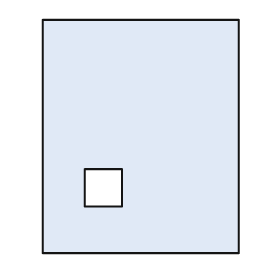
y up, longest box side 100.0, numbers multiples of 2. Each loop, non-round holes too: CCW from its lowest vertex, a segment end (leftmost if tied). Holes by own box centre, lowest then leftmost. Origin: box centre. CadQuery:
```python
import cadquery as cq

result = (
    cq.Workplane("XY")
    .moveTo(-42.0, -50.0)
    .lineTo(42.0, -50.0)
    .lineTo(42.0, 50.0)
    .lineTo(-42.0, 50.0)
    .close()
    .moveTo(-24.0, -30.0)
    .lineTo(-8.0, -30.0)
    .lineTo(-8.0, -14.0)
    .lineTo(-24.0, -14.0)
    .close()
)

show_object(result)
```